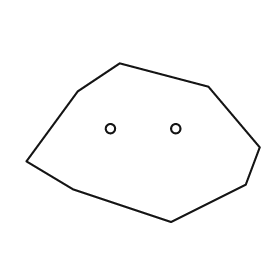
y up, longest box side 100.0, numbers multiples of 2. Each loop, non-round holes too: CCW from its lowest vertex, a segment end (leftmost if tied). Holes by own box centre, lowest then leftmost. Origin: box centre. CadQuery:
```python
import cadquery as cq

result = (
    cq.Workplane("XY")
    .moveTo(12.0, -34.0)
    .lineTo(44.0, -18.0)
    .lineTo(50.0, -2.0)
    .lineTo(28.0, 24.0)
    .lineTo(-10.0, 34.0)
    .lineTo(-28.0, 22.0)
    .lineTo(-50.0, -8.0)
    .lineTo(-30.0, -20.0)
    .close()
    .moveTo(-14.0, 6.0)
    .circle(2.0)
    .moveTo(14.0, 6.0)
    .circle(2.0)
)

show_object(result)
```